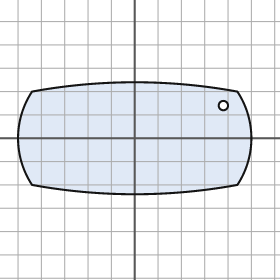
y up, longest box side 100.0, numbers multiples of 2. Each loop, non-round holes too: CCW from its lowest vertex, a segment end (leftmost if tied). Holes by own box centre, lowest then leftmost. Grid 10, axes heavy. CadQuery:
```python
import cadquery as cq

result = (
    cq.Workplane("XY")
    .moveTo(-44.0, -20.0)
    .threePointArc((0.0, -24.0), (44.0, -20.0))
    .threePointArc((50.0, 0.0), (44.0, 20.0))
    .threePointArc((0.0, 24.0), (-44.0, 20.0))
    .threePointArc((-50.0, 0.0), (-44.0, -20.0))
    .close()
    .moveTo(38.0, 14.0)
    .circle(2.0)
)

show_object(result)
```